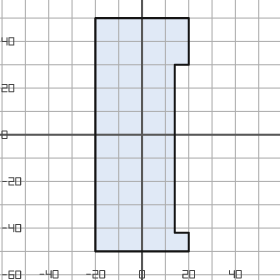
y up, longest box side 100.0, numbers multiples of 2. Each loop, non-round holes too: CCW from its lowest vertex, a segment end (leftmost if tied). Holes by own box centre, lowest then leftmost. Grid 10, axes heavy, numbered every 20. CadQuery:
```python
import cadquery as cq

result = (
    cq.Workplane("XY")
    .moveTo(-20.0, -50.0)
    .lineTo(20.0, -50.0)
    .lineTo(20.0, -42.0)
    .lineTo(14.0, -42.0)
    .lineTo(14.0, 30.0)
    .lineTo(20.0, 30.0)
    .lineTo(20.0, 50.0)
    .lineTo(-20.0, 50.0)
    .close()
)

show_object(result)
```